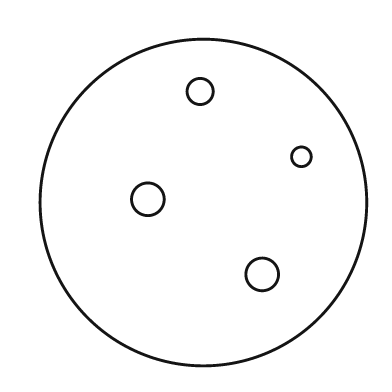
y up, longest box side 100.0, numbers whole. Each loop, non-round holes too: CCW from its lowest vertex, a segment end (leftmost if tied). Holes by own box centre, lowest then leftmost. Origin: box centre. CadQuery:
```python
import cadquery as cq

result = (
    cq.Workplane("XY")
    .moveTo(0.0, 0.0)
    .circle(50.0)
    .moveTo(18.0, -22.0)
    .circle(5.0)
    .moveTo(-17.0, 1.0)
    .circle(5.0)
    .moveTo(30.0, 14.0)
    .circle(3.0)
    .moveTo(-1.0, 34.0)
    .circle(4.0)
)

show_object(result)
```